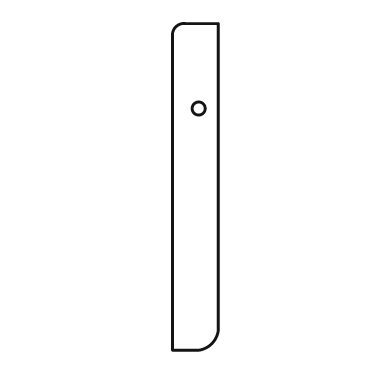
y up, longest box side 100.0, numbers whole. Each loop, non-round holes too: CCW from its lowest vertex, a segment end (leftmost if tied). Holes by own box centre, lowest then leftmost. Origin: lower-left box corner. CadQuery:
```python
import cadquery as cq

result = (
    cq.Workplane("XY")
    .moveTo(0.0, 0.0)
    .lineTo(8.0, 0.0)
    .threePointArc((12.0, 2.0), (14.0, 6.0))
    .lineTo(14.0, 100.0)
    .lineTo(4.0, 100.0)
    .threePointArc((1.0, 99.0), (0.0, 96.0))
    .close()
    .moveTo(8.0, 74.0)
    .circle(2.0)
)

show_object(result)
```